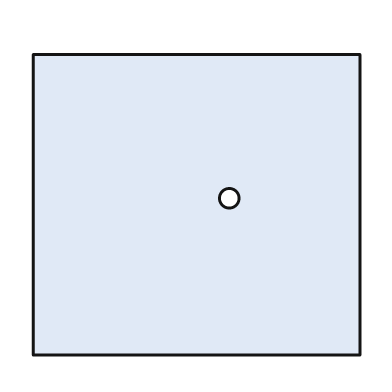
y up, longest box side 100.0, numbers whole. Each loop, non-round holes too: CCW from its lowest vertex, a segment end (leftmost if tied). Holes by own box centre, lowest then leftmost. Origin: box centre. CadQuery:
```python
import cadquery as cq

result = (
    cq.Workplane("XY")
    .moveTo(-50.0, -46.0)
    .lineTo(50.0, -46.0)
    .lineTo(50.0, 46.0)
    .lineTo(-50.0, 46.0)
    .close()
    .moveTo(10.0, 2.0)
    .circle(3.0)
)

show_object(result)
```